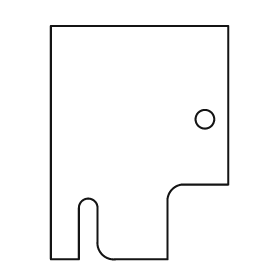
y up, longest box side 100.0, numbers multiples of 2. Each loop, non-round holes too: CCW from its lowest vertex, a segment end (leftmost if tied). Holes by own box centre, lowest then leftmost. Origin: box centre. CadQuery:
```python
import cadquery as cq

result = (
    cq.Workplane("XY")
    .moveTo(-38.0, -50.0)
    .lineTo(-26.0, -50.0)
    .lineTo(-26.0, -28.0)
    .threePointArc((-22.0, -24.0), (-18.0, -28.0))
    .lineTo(-18.0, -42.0)
    .threePointArc((-16.0, -48.0), (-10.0, -50.0))
    .lineTo(12.0, -50.0)
    .lineTo(12.0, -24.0)
    .threePointArc((14.0, -20.0), (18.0, -18.0))
    .lineTo(38.0, -18.0)
    .lineTo(38.0, 50.0)
    .lineTo(-38.0, 50.0)
    .close()
    .moveTo(28.0, 10.0)
    .circle(4.0)
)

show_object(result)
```